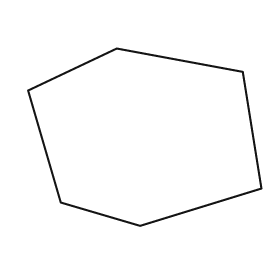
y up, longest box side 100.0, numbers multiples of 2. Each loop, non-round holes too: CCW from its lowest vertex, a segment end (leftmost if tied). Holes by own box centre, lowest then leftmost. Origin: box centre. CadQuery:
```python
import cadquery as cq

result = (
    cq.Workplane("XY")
    .moveTo(-2.0, -38.0)
    .lineTo(50.0, -22.0)
    .lineTo(42.0, 28.0)
    .lineTo(-12.0, 38.0)
    .lineTo(-50.0, 20.0)
    .lineTo(-36.0, -28.0)
    .close()
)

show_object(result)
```